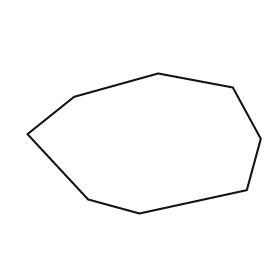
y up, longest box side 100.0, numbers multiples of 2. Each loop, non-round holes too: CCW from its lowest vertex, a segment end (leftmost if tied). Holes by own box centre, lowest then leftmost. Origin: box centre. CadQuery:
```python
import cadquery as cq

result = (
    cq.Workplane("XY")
    .moveTo(-2.0, -30.0)
    .lineTo(44.0, -20.0)
    .lineTo(50.0, 2.0)
    .lineTo(38.0, 24.0)
    .lineTo(6.0, 30.0)
    .lineTo(-30.0, 20.0)
    .lineTo(-50.0, 4.0)
    .lineTo(-24.0, -24.0)
    .close()
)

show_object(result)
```